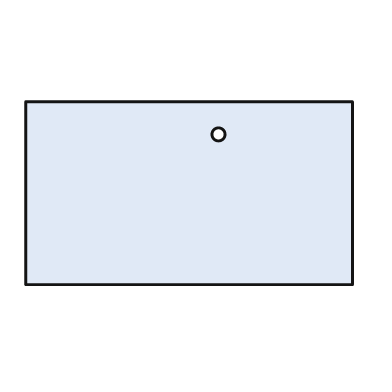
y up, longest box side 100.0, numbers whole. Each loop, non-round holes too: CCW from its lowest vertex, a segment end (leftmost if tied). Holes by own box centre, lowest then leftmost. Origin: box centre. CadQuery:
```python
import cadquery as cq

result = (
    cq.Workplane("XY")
    .moveTo(-50.0, -28.0)
    .lineTo(50.0, -28.0)
    .lineTo(50.0, 28.0)
    .lineTo(-50.0, 28.0)
    .close()
    .moveTo(9.0, 18.0)
    .circle(2.0)
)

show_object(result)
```